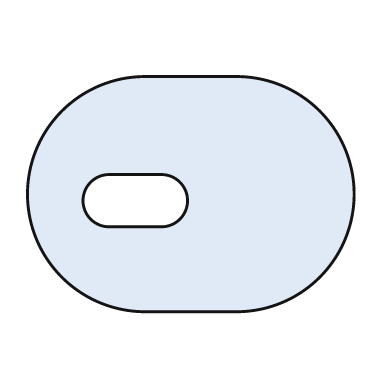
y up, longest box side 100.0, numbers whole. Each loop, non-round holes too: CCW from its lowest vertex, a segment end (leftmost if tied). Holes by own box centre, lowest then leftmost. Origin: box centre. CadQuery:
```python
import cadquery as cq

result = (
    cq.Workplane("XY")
    .moveTo(-14.0, -36.0)
    .lineTo(14.0, -36.0)
    .threePointArc((50.0, 0.0), (14.0, 36.0))
    .lineTo(-14.0, 36.0)
    .threePointArc((-50.0, 0.0), (-14.0, -36.0))
    .close()
    .moveTo(-25.0, -10.0)
    .lineTo(-9.0, -10.0)
    .threePointArc((-1.0, -2.0), (-9.0, 6.0))
    .lineTo(-25.0, 6.0)
    .threePointArc((-33.0, -2.0), (-25.0, -10.0))
    .close()
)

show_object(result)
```